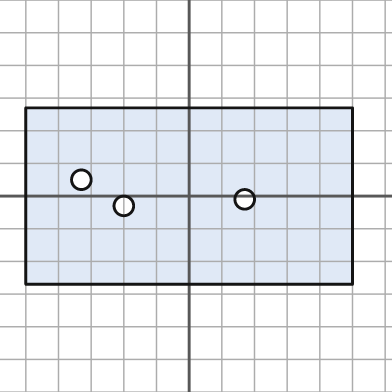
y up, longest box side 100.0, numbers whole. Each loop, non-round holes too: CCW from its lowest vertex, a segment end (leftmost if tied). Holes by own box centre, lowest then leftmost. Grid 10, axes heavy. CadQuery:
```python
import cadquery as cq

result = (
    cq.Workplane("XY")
    .moveTo(-50.0, -27.0)
    .lineTo(50.0, -27.0)
    .lineTo(50.0, 27.0)
    .lineTo(-50.0, 27.0)
    .close()
    .moveTo(-20.0, -3.0)
    .circle(3.0)
    .moveTo(17.0, -1.0)
    .circle(3.0)
    .moveTo(-33.0, 5.0)
    .circle(3.0)
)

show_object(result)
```